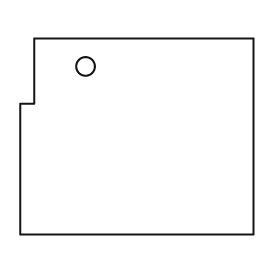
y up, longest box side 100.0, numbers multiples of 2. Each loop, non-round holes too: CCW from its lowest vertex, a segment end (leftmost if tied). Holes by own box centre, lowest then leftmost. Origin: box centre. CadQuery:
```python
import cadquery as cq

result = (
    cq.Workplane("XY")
    .moveTo(-50.0, -42.0)
    .lineTo(50.0, -42.0)
    .lineTo(50.0, 42.0)
    .lineTo(-44.0, 42.0)
    .lineTo(-44.0, 14.0)
    .lineTo(-50.0, 14.0)
    .close()
    .moveTo(-22.0, 30.0)
    .circle(4.0)
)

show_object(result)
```